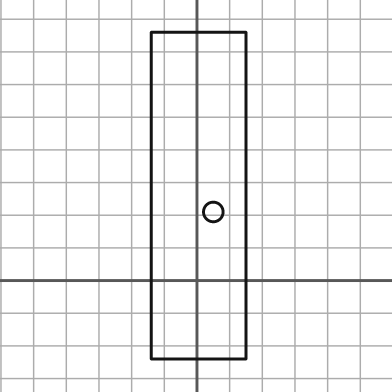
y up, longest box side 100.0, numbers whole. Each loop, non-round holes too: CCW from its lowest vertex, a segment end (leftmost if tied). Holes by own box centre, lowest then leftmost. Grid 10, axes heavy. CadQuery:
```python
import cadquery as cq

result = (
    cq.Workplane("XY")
    .moveTo(-14.0, -24.0)
    .lineTo(15.0, -24.0)
    .lineTo(15.0, 76.0)
    .lineTo(-14.0, 76.0)
    .close()
    .moveTo(5.0, 21.0)
    .circle(3.0)
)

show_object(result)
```